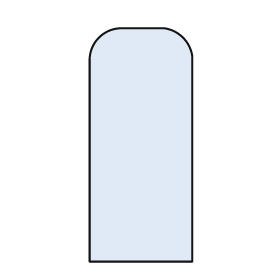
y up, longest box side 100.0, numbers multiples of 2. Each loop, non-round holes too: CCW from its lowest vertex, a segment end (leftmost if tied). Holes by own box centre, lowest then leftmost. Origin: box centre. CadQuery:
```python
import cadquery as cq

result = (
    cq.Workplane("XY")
    .moveTo(-22.0, -50.0)
    .lineTo(22.0, -50.0)
    .lineTo(22.0, 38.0)
    .threePointArc((18.0, 46.0), (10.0, 50.0))
    .lineTo(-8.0, 50.0)
    .threePointArc((-18.0, 46.0), (-22.0, 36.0))
    .close()
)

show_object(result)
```